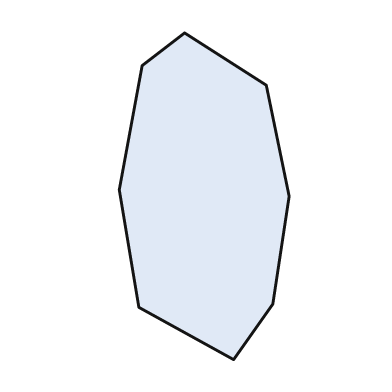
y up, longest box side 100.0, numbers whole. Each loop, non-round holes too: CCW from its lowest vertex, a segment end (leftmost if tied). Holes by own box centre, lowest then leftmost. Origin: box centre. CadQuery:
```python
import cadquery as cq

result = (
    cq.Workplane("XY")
    .moveTo(9.0, -50.0)
    .lineTo(21.0, -33.0)
    .lineTo(26.0, 0.0)
    .lineTo(19.0, 34.0)
    .lineTo(-6.0, 50.0)
    .lineTo(-19.0, 40.0)
    .lineTo(-26.0, 2.0)
    .lineTo(-20.0, -34.0)
    .close()
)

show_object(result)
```